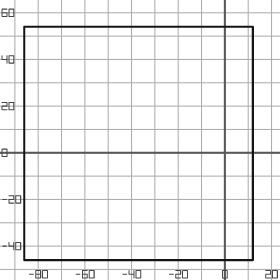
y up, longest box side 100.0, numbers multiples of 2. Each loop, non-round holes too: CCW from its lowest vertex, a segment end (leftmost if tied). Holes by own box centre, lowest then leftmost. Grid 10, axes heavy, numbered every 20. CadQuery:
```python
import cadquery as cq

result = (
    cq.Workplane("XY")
    .moveTo(-86.0, -46.0)
    .lineTo(12.0, -46.0)
    .lineTo(12.0, 54.0)
    .lineTo(-86.0, 54.0)
    .close()
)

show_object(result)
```